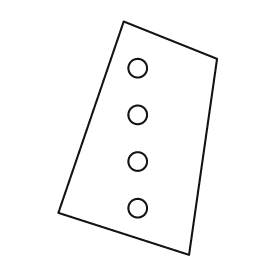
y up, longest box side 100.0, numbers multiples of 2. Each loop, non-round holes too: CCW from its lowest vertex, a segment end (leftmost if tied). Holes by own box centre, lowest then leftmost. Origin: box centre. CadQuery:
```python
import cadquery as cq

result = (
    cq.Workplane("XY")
    .moveTo(22.0, -50.0)
    .lineTo(34.0, 34.0)
    .lineTo(-6.0, 50.0)
    .lineTo(-34.0, -32.0)
    .close()
    .moveTo(0.0, -30.0)
    .circle(4.0)
    .moveTo(0.0, -10.0)
    .circle(4.0)
    .moveTo(0.0, 10.0)
    .circle(4.0)
    .moveTo(0.0, 30.0)
    .circle(4.0)
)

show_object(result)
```